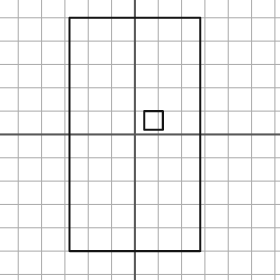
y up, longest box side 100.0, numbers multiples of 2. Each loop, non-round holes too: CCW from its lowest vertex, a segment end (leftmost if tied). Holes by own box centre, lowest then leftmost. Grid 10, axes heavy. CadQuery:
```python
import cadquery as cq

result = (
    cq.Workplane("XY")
    .moveTo(-28.0, -50.0)
    .lineTo(28.0, -50.0)
    .lineTo(28.0, 50.0)
    .lineTo(-28.0, 50.0)
    .close()
    .moveTo(4.0, 2.0)
    .lineTo(12.0, 2.0)
    .lineTo(12.0, 10.0)
    .lineTo(4.0, 10.0)
    .close()
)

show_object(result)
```